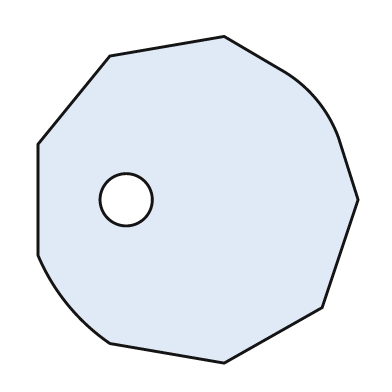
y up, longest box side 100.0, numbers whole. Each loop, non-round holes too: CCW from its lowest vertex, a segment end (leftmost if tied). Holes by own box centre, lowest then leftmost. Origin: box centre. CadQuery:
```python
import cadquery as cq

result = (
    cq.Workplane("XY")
    .moveTo(8.0, -50.0)
    .lineTo(38.0, -33.0)
    .lineTo(49.0, 0.0)
    .lineTo(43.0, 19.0)
    .threePointArc((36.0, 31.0), (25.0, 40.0))
    .lineTo(8.0, 50.0)
    .lineTo(-27.0, 44.0)
    .lineTo(-49.0, 17.0)
    .lineTo(-49.0, -17.0)
    .threePointArc((-40.0, -32.0), (-27.0, -44.0))
    .close()
    .moveTo(-22.0, 0.0)
    .circle(8.0)
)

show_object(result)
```